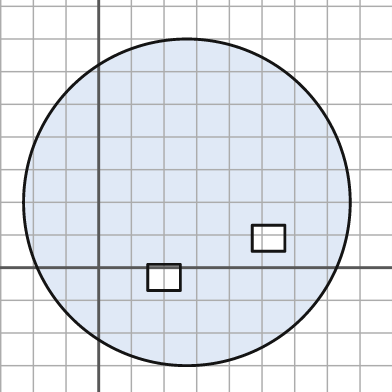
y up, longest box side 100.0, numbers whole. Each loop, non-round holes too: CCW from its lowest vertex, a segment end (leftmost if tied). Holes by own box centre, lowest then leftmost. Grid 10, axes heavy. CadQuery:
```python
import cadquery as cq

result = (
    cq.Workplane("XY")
    .moveTo(27.0, 20.0)
    .circle(50.0)
    .moveTo(15.0, -7.0)
    .lineTo(25.0, -7.0)
    .lineTo(25.0, 1.0)
    .lineTo(15.0, 1.0)
    .close()
    .moveTo(47.0, 5.0)
    .lineTo(57.0, 5.0)
    .lineTo(57.0, 13.0)
    .lineTo(47.0, 13.0)
    .close()
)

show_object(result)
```